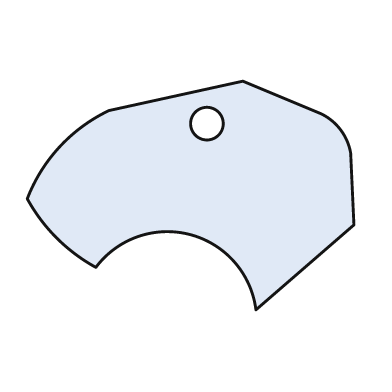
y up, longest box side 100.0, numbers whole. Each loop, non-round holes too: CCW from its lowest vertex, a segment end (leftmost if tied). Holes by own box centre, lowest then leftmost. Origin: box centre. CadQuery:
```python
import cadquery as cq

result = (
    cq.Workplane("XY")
    .moveTo(20.0, -35.0)
    .lineTo(50.0, -9.0)
    .lineTo(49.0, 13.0)
    .threePointArc((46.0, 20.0), (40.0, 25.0))
    .lineTo(16.0, 35.0)
    .lineTo(-25.0, 26.0)
    .threePointArc((-40.0, 15.0), (-50.0, -1.0))
    .threePointArc((-41.0, -13.0), (-29.0, -22.0))
    .threePointArc((0.0, -12.0), (20.0, -35.0))
    .close()
    .moveTo(5.0, 22.0)
    .circle(5.0)
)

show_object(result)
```